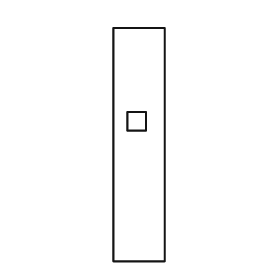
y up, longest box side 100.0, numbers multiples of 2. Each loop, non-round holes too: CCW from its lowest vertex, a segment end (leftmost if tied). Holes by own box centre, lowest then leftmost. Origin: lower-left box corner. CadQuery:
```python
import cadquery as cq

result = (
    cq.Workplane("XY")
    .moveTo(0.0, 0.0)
    .lineTo(22.0, 0.0)
    .lineTo(22.0, 100.0)
    .lineTo(0.0, 100.0)
    .close()
    .moveTo(6.0, 56.0)
    .lineTo(14.0, 56.0)
    .lineTo(14.0, 64.0)
    .lineTo(6.0, 64.0)
    .close()
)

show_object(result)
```